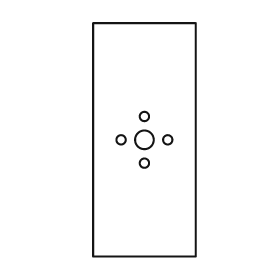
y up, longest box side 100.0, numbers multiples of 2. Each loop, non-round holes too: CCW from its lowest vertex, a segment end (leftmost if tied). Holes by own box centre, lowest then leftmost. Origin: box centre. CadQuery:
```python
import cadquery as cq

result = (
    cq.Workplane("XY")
    .moveTo(-22.0, -50.0)
    .lineTo(22.0, -50.0)
    .lineTo(22.0, 50.0)
    .lineTo(-22.0, 50.0)
    .close()
    .moveTo(0.0, -10.0)
    .circle(2.0)
    .moveTo(-10.0, 0.0)
    .circle(2.0)
    .moveTo(0.0, 0.0)
    .circle(4.0)
    .moveTo(10.0, 0.0)
    .circle(2.0)
    .moveTo(0.0, 10.0)
    .circle(2.0)
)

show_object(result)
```